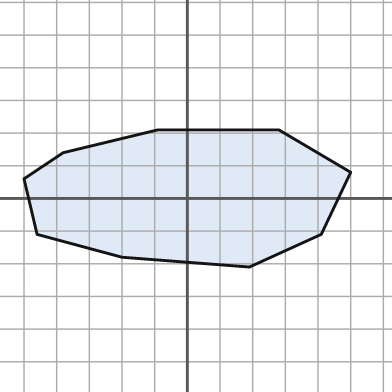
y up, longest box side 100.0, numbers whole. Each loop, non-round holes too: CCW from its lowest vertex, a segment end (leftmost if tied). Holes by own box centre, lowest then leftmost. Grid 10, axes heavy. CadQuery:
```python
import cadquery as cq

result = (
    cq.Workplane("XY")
    .moveTo(19.0, -21.0)
    .lineTo(41.0, -11.0)
    .lineTo(50.0, 8.0)
    .lineTo(28.0, 21.0)
    .lineTo(-9.0, 21.0)
    .lineTo(-38.0, 14.0)
    .lineTo(-50.0, 6.0)
    .lineTo(-46.0, -11.0)
    .lineTo(-20.0, -18.0)
    .close()
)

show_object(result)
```